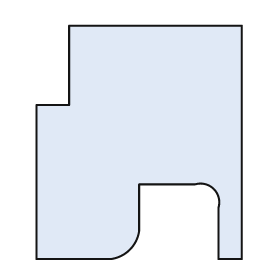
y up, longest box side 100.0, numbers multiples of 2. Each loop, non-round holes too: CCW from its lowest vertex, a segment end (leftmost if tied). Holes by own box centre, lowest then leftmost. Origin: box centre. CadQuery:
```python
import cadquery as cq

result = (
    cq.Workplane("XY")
    .moveTo(-44.0, -50.0)
    .lineTo(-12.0, -50.0)
    .threePointArc((-4.0, -46.0), (0.0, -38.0))
    .lineTo(0.0, -18.0)
    .lineTo(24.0, -18.0)
    .threePointArc((32.0, -20.0), (34.0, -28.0))
    .lineTo(34.0, -50.0)
    .lineTo(44.0, -50.0)
    .lineTo(44.0, 50.0)
    .lineTo(-30.0, 50.0)
    .lineTo(-30.0, 16.0)
    .lineTo(-44.0, 16.0)
    .close()
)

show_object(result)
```